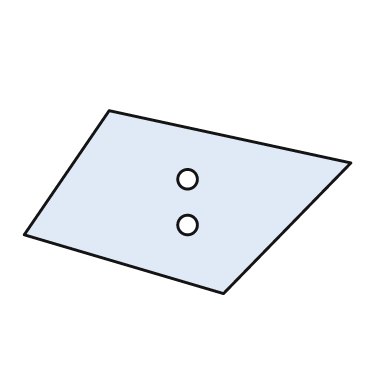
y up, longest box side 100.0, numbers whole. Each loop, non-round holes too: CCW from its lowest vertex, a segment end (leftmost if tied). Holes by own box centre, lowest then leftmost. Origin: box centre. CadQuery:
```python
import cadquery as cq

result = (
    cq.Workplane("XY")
    .moveTo(11.0, -28.0)
    .lineTo(50.0, 12.0)
    .lineTo(-24.0, 28.0)
    .lineTo(-50.0, -10.0)
    .close()
    .moveTo(0.0, -7.0)
    .circle(3.0)
    .moveTo(0.0, 7.0)
    .circle(3.0)
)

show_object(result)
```